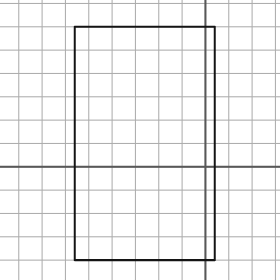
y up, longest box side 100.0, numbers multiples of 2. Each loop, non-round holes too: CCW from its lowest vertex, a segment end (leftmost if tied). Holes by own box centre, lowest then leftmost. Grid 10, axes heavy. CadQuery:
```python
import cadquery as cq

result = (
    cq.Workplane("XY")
    .moveTo(-56.0, -40.0)
    .lineTo(4.0, -40.0)
    .lineTo(4.0, 60.0)
    .lineTo(-56.0, 60.0)
    .close()
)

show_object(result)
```